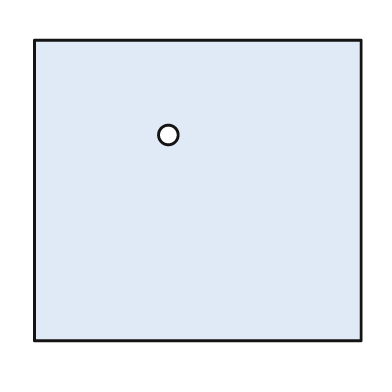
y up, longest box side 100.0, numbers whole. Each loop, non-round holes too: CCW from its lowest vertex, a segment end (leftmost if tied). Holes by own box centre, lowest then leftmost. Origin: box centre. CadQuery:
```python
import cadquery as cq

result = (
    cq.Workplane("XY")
    .moveTo(-50.0, -46.0)
    .lineTo(50.0, -46.0)
    .lineTo(50.0, 46.0)
    .lineTo(-50.0, 46.0)
    .close()
    .moveTo(-9.0, 17.0)
    .circle(3.0)
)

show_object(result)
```